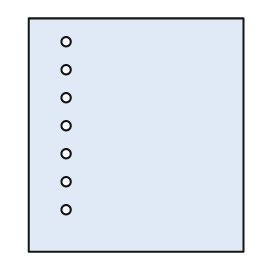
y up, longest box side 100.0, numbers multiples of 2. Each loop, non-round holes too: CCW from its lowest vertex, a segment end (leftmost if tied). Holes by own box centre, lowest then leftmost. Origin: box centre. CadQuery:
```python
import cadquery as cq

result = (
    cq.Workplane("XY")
    .moveTo(-46.0, -50.0)
    .lineTo(46.0, -50.0)
    .lineTo(46.0, 50.0)
    .lineTo(-46.0, 50.0)
    .close()
    .moveTo(-30.0, -32.0)
    .circle(2.0)
    .moveTo(-30.0, -20.0)
    .circle(2.0)
    .moveTo(-30.0, -8.0)
    .circle(2.0)
    .moveTo(-30.0, 4.0)
    .circle(2.0)
    .moveTo(-30.0, 16.0)
    .circle(2.0)
    .moveTo(-30.0, 28.0)
    .circle(2.0)
    .moveTo(-30.0, 40.0)
    .circle(2.0)
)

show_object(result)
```